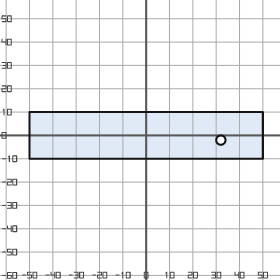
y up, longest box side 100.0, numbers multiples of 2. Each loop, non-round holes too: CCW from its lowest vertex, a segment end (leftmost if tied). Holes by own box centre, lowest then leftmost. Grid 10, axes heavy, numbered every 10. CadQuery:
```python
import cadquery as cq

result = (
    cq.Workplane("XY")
    .moveTo(-50.0, -10.0)
    .lineTo(50.0, -10.0)
    .lineTo(50.0, 10.0)
    .lineTo(-50.0, 10.0)
    .close()
    .moveTo(32.0, -2.0)
    .circle(2.0)
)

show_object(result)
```